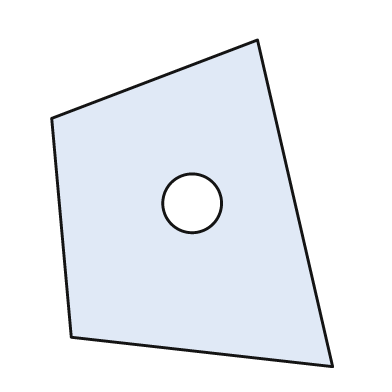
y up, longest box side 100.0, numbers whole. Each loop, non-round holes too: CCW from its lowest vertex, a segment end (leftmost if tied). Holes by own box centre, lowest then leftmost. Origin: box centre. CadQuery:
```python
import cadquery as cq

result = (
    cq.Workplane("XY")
    .moveTo(43.0, -50.0)
    .lineTo(20.0, 50.0)
    .lineTo(-43.0, 26.0)
    .lineTo(-37.0, -41.0)
    .close()
    .moveTo(0.0, 0.0)
    .circle(9.0)
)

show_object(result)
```